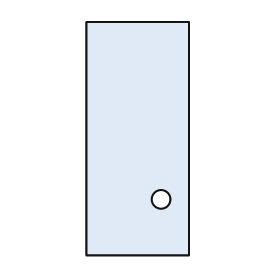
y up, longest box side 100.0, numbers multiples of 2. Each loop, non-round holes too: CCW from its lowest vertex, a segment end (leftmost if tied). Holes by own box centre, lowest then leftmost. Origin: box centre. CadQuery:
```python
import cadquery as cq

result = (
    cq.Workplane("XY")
    .moveTo(-22.0, -50.0)
    .lineTo(22.0, -50.0)
    .lineTo(22.0, 50.0)
    .lineTo(-22.0, 50.0)
    .close()
    .moveTo(10.0, -26.0)
    .circle(4.0)
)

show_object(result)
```